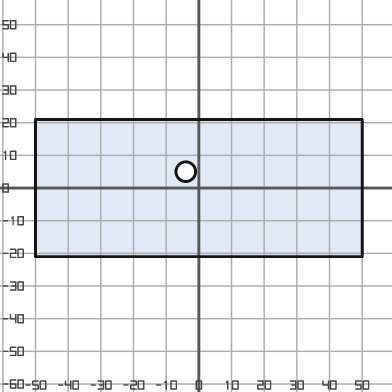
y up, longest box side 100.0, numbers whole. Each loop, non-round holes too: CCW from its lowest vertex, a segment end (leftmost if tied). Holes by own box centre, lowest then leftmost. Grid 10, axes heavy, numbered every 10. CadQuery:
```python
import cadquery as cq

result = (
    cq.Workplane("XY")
    .moveTo(-50.0, -21.0)
    .lineTo(50.0, -21.0)
    .lineTo(50.0, 21.0)
    .lineTo(-50.0, 21.0)
    .close()
    .moveTo(-4.0, 5.0)
    .circle(3.0)
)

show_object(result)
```